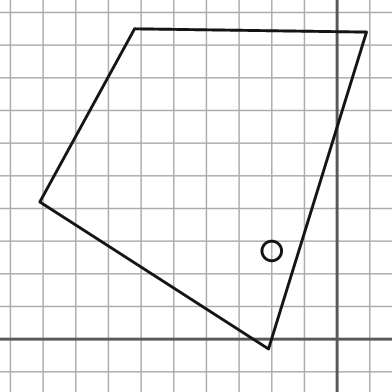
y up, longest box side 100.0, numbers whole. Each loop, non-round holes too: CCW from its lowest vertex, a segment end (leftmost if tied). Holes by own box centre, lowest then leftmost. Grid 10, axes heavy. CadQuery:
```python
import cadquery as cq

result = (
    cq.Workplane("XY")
    .moveTo(-21.0, -3.0)
    .lineTo(9.0, 94.0)
    .lineTo(-62.0, 95.0)
    .lineTo(-91.0, 42.0)
    .close()
    .moveTo(-20.0, 27.0)
    .circle(3.0)
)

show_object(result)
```